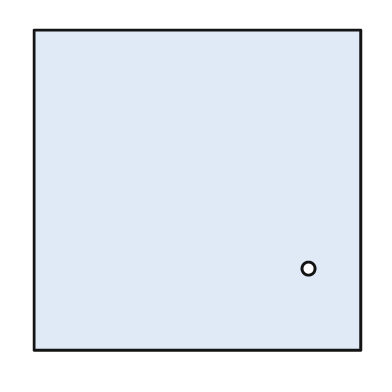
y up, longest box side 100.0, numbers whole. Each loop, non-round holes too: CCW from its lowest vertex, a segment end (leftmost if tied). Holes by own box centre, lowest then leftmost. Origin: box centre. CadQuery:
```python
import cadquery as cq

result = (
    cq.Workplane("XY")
    .moveTo(-50.0, -49.0)
    .lineTo(50.0, -49.0)
    .lineTo(50.0, 49.0)
    .lineTo(-50.0, 49.0)
    .close()
    .moveTo(34.0, -24.0)
    .circle(2.0)
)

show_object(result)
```